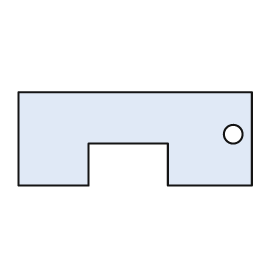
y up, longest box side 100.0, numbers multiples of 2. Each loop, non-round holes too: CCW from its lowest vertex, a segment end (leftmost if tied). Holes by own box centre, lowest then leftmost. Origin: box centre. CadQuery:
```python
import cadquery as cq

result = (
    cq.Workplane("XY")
    .moveTo(-50.0, -20.0)
    .lineTo(-20.0, -20.0)
    .lineTo(-20.0, -2.0)
    .lineTo(14.0, -2.0)
    .lineTo(14.0, -20.0)
    .lineTo(50.0, -20.0)
    .lineTo(50.0, 20.0)
    .lineTo(-50.0, 20.0)
    .close()
    .moveTo(42.0, 2.0)
    .circle(4.0)
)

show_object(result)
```